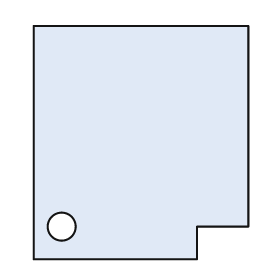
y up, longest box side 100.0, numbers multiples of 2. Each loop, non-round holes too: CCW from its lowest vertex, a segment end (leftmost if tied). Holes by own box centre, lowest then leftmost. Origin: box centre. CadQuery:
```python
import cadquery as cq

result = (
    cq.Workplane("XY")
    .moveTo(-46.0, -50.0)
    .lineTo(24.0, -50.0)
    .lineTo(24.0, -36.0)
    .lineTo(46.0, -36.0)
    .lineTo(46.0, 50.0)
    .lineTo(-46.0, 50.0)
    .close()
    .moveTo(-34.0, -36.0)
    .circle(6.0)
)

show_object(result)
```